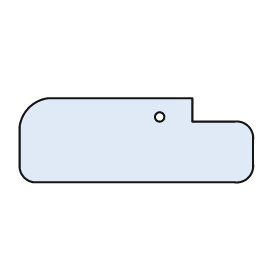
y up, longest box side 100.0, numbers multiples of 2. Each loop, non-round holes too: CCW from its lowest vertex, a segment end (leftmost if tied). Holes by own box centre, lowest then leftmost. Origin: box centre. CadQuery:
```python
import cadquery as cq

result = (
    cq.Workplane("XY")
    .moveTo(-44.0, -18.0)
    .lineTo(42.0, -18.0)
    .threePointArc((48.0, -16.0), (50.0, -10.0))
    .lineTo(50.0, 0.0)
    .threePointArc((48.0, 6.0), (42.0, 8.0))
    .lineTo(24.0, 8.0)
    .lineTo(24.0, 18.0)
    .lineTo(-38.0, 18.0)
    .threePointArc((-46.0, 14.0), (-50.0, 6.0))
    .lineTo(-50.0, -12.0)
    .threePointArc((-48.0, -16.0), (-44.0, -18.0))
    .close()
    .moveTo(10.0, 10.0)
    .circle(2.0)
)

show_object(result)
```